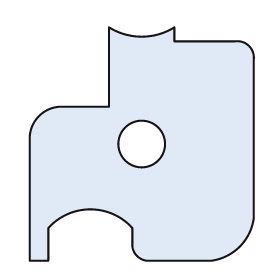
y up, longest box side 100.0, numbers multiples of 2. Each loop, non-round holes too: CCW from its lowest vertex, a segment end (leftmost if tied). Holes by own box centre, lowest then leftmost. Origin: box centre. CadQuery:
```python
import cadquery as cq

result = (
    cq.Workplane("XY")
    .moveTo(-48.0, -50.0)
    .lineTo(-40.0, -50.0)
    .lineTo(-40.0, -36.0)
    .threePointArc((-22.0, -28.0), (-4.0, -36.0))
    .lineTo(-4.0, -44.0)
    .threePointArc((-2.0, -48.0), (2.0, -50.0))
    .lineTo(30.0, -50.0)
    .threePointArc((42.0, -44.0), (48.0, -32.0))
    .lineTo(48.0, 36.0)
    .threePointArc((46.0, 42.0), (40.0, 44.0))
    .lineTo(14.0, 44.0)
    .lineTo(14.0, 50.0)
    .threePointArc((0.0, 46.0), (-14.0, 50.0))
    .lineTo(-14.0, 16.0)
    .lineTo(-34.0, 16.0)
    .threePointArc((-44.0, 12.0), (-48.0, 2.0))
    .close()
    .moveTo(0.0, 0.0)
    .circle(10.0)
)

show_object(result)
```